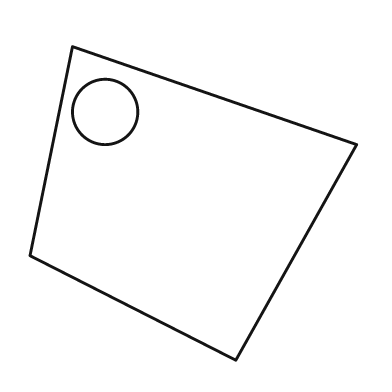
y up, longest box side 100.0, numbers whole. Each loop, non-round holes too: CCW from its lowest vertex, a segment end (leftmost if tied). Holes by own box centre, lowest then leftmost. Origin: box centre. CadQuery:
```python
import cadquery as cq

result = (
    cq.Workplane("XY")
    .moveTo(13.0, -48.0)
    .lineTo(50.0, 18.0)
    .lineTo(-37.0, 48.0)
    .lineTo(-50.0, -16.0)
    .close()
    .moveTo(-27.0, 28.0)
    .circle(10.0)
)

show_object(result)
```